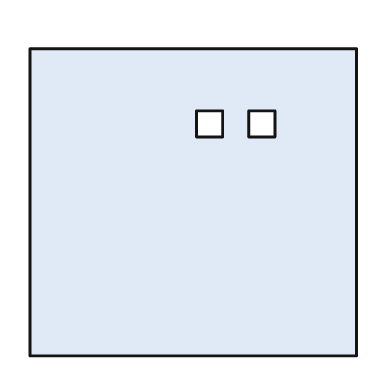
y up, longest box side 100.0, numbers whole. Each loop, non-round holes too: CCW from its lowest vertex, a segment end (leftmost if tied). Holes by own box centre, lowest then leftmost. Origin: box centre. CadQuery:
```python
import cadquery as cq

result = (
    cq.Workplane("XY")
    .moveTo(-50.0, -47.0)
    .lineTo(50.0, -47.0)
    .lineTo(50.0, 47.0)
    .lineTo(-50.0, 47.0)
    .close()
    .moveTo(1.0, 20.0)
    .lineTo(9.0, 20.0)
    .lineTo(9.0, 28.0)
    .lineTo(1.0, 28.0)
    .close()
    .moveTo(17.0, 20.0)
    .lineTo(25.0, 20.0)
    .lineTo(25.0, 28.0)
    .lineTo(17.0, 28.0)
    .close()
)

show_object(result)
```